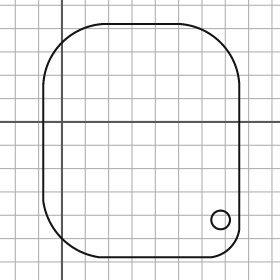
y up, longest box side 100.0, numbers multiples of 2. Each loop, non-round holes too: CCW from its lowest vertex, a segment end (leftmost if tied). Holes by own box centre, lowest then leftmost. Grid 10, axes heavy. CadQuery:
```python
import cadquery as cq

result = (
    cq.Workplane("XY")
    .moveTo(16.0, -58.0)
    .lineTo(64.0, -58.0)
    .threePointArc((72.0, -54.0), (76.0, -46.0))
    .lineTo(76.0, 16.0)
    .threePointArc((68.0, 34.0), (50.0, 42.0))
    .lineTo(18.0, 42.0)
    .threePointArc((0.0, 34.0), (-8.0, 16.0))
    .lineTo(-8.0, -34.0)
    .threePointArc((0.0, -50.0), (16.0, -58.0))
    .close()
    .moveTo(68.0, -42.0)
    .circle(4.0)
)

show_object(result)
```